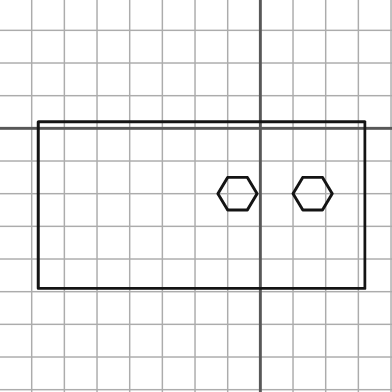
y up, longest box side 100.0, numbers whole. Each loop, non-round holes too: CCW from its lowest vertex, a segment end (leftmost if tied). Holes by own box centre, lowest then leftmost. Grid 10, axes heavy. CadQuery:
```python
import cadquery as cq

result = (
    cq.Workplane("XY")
    .moveTo(-68.0, -49.0)
    .lineTo(32.0, -49.0)
    .lineTo(32.0, 2.0)
    .lineTo(-68.0, 2.0)
    .close()
    .moveTo(-10.0, -25.0)
    .lineTo(-4.0, -25.0)
    .lineTo(-1.0, -20.0)
    .lineTo(-4.0, -15.0)
    .lineTo(-10.0, -15.0)
    .lineTo(-13.0, -20.0)
    .close()
    .moveTo(13.0, -25.0)
    .lineTo(19.0, -25.0)
    .lineTo(22.0, -20.0)
    .lineTo(19.0, -15.0)
    .lineTo(13.0, -15.0)
    .lineTo(10.0, -20.0)
    .close()
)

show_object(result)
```